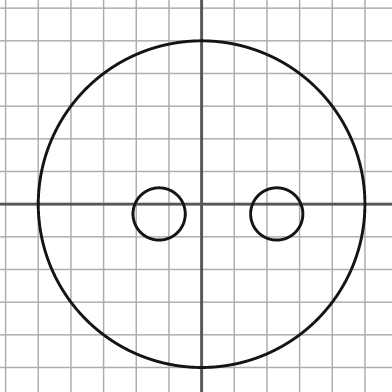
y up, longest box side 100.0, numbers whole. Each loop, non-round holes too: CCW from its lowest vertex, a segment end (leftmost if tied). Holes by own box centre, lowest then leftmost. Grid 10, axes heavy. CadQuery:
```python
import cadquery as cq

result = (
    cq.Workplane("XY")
    .moveTo(0.0, 0.0)
    .circle(50.0)
    .moveTo(-13.0, -3.0)
    .circle(8.0)
    .moveTo(23.0, -3.0)
    .circle(8.0)
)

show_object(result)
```